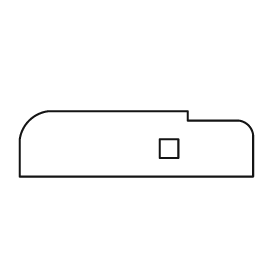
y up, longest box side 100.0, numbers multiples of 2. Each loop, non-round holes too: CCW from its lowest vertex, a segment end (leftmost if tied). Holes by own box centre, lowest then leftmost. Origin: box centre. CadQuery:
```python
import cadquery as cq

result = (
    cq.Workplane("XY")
    .moveTo(-50.0, -14.0)
    .lineTo(50.0, -14.0)
    .lineTo(50.0, 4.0)
    .threePointArc((48.0, 8.0), (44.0, 10.0))
    .lineTo(22.0, 10.0)
    .lineTo(22.0, 14.0)
    .lineTo(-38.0, 14.0)
    .threePointArc((-46.0, 10.0), (-50.0, 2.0))
    .close()
    .moveTo(10.0, -6.0)
    .lineTo(18.0, -6.0)
    .lineTo(18.0, 2.0)
    .lineTo(10.0, 2.0)
    .close()
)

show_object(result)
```